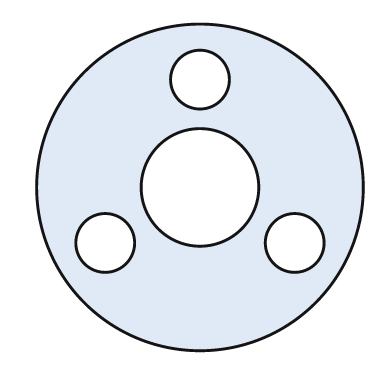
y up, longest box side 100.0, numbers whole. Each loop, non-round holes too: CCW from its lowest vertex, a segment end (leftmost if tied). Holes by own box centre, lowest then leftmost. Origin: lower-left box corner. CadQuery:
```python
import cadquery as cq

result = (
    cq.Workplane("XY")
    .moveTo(50.0, 50.0)
    .circle(50.0)
    .moveTo(21.0, 33.0)
    .circle(9.0)
    .moveTo(79.0, 33.0)
    .circle(9.0)
    .moveTo(50.0, 50.0)
    .circle(18.0)
    .moveTo(50.0, 83.0)
    .circle(9.0)
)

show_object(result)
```